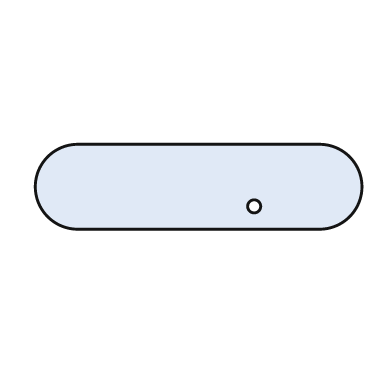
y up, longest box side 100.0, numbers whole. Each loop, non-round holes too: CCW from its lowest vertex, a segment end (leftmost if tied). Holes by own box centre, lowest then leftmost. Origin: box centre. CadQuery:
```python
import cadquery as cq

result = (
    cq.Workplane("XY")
    .moveTo(-37.0, -13.0)
    .lineTo(37.0, -13.0)
    .threePointArc((50.0, 0.0), (37.0, 13.0))
    .lineTo(-37.0, 13.0)
    .threePointArc((-50.0, 0.0), (-37.0, -13.0))
    .close()
    .moveTo(17.0, -6.0)
    .circle(2.0)
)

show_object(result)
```